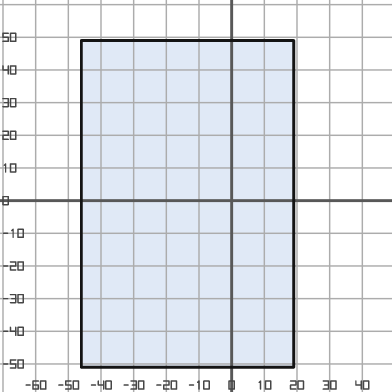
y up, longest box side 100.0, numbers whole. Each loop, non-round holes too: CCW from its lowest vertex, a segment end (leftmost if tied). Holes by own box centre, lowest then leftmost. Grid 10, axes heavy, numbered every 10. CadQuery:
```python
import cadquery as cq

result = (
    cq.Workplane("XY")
    .moveTo(-46.0, -51.0)
    .lineTo(19.0, -51.0)
    .lineTo(19.0, 49.0)
    .lineTo(-46.0, 49.0)
    .close()
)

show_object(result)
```